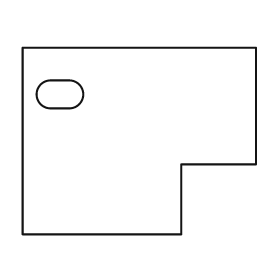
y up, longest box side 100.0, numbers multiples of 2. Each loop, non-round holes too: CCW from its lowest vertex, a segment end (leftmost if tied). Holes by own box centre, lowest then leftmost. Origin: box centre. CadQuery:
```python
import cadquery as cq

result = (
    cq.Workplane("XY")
    .moveTo(-50.0, -40.0)
    .lineTo(18.0, -40.0)
    .lineTo(18.0, -10.0)
    .lineTo(50.0, -10.0)
    .lineTo(50.0, 40.0)
    .lineTo(-50.0, 40.0)
    .close()
    .moveTo(-38.0, 14.0)
    .lineTo(-30.0, 14.0)
    .threePointArc((-24.0, 20.0), (-30.0, 26.0))
    .lineTo(-38.0, 26.0)
    .threePointArc((-44.0, 20.0), (-38.0, 14.0))
    .close()
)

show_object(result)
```